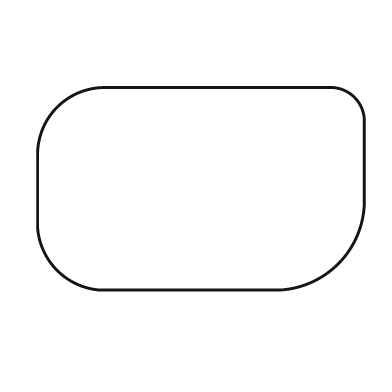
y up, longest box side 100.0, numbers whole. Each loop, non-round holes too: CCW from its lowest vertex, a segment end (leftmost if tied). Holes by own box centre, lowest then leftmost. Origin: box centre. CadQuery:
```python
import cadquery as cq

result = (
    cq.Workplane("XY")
    .moveTo(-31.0, -31.0)
    .lineTo(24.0, -31.0)
    .threePointArc((42.0, -23.0), (50.0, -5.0))
    .lineTo(50.0, 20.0)
    .threePointArc((47.0, 28.0), (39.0, 31.0))
    .lineTo(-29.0, 31.0)
    .threePointArc((-44.0, 25.0), (-50.0, 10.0))
    .lineTo(-50.0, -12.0)
    .threePointArc((-44.0, -25.0), (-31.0, -31.0))
    .close()
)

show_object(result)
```